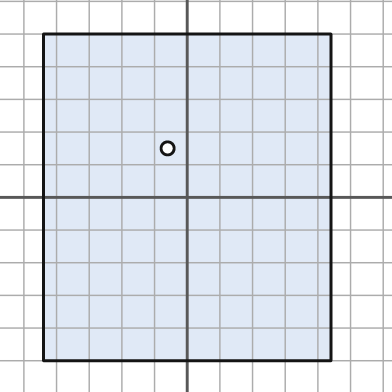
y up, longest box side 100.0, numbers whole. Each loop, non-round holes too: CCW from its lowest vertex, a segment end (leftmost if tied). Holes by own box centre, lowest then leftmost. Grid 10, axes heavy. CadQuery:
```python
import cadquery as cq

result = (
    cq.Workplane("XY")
    .moveTo(-44.0, -50.0)
    .lineTo(44.0, -50.0)
    .lineTo(44.0, 50.0)
    .lineTo(-44.0, 50.0)
    .close()
    .moveTo(-6.0, 15.0)
    .circle(2.0)
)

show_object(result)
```